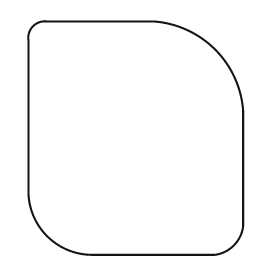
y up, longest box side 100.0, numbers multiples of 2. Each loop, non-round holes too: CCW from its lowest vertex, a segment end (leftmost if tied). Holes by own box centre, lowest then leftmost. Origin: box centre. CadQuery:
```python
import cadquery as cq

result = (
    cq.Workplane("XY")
    .moveTo(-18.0, -50.0)
    .lineTo(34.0, -50.0)
    .threePointArc((42.0, -46.0), (46.0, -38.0))
    .lineTo(46.0, 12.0)
    .threePointArc((34.0, 38.0), (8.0, 50.0))
    .lineTo(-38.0, 50.0)
    .threePointArc((-44.0, 48.0), (-46.0, 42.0))
    .lineTo(-46.0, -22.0)
    .threePointArc((-38.0, -42.0), (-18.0, -50.0))
    .close()
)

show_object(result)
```